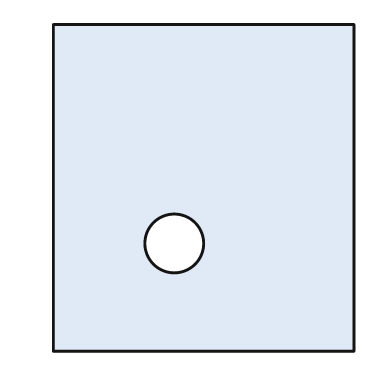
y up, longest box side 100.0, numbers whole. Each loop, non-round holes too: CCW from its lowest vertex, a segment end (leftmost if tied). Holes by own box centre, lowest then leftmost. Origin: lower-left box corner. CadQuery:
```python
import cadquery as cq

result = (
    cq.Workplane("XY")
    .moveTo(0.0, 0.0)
    .lineTo(92.0, 0.0)
    .lineTo(92.0, 100.0)
    .lineTo(0.0, 100.0)
    .close()
    .moveTo(37.0, 33.0)
    .circle(9.0)
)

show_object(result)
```